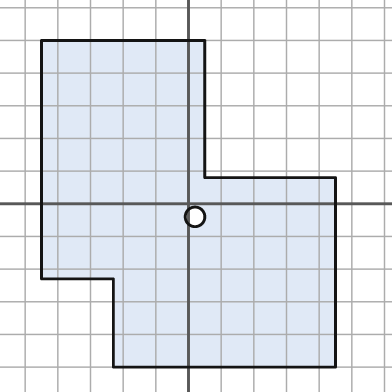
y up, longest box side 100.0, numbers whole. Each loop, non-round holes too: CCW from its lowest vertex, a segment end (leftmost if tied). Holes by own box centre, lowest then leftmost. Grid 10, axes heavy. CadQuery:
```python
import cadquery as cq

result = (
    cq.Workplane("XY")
    .moveTo(-23.0, -50.0)
    .lineTo(45.0, -50.0)
    .lineTo(45.0, 8.0)
    .lineTo(5.0, 8.0)
    .lineTo(5.0, 50.0)
    .lineTo(-45.0, 50.0)
    .lineTo(-45.0, -23.0)
    .lineTo(-23.0, -23.0)
    .close()
    .moveTo(2.0, -4.0)
    .circle(3.0)
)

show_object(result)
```